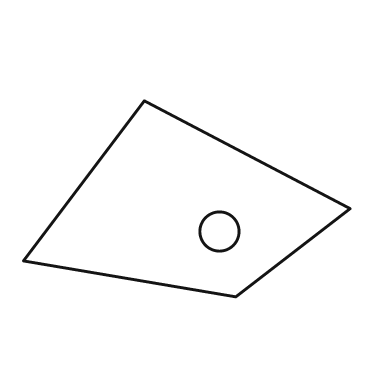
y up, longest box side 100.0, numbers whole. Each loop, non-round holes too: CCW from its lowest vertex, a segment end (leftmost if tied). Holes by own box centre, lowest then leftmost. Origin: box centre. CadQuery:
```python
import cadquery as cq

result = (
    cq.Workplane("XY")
    .moveTo(15.0, -30.0)
    .lineTo(50.0, -3.0)
    .lineTo(-13.0, 30.0)
    .lineTo(-50.0, -19.0)
    .close()
    .moveTo(10.0, -10.0)
    .circle(6.0)
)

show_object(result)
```